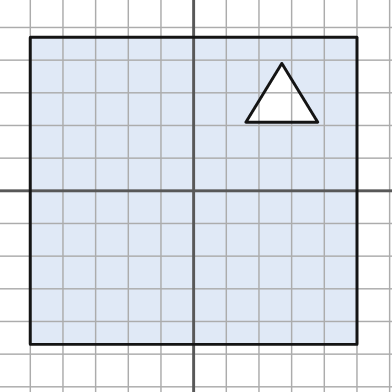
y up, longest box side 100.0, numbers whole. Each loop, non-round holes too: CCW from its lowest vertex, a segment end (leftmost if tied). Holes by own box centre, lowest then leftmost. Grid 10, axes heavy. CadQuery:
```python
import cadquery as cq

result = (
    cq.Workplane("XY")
    .moveTo(-50.0, -47.0)
    .lineTo(50.0, -47.0)
    .lineTo(50.0, 47.0)
    .lineTo(-50.0, 47.0)
    .close()
    .moveTo(16.0, 21.0)
    .lineTo(38.0, 21.0)
    .lineTo(27.0, 39.0)
    .close()
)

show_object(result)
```